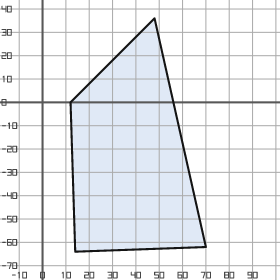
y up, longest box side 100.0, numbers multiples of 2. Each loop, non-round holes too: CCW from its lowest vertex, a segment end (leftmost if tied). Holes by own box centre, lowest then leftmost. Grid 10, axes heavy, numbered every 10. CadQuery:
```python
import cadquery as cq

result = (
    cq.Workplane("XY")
    .moveTo(14.0, -64.0)
    .lineTo(70.0, -62.0)
    .lineTo(48.0, 36.0)
    .lineTo(12.0, 0.0)
    .close()
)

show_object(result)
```